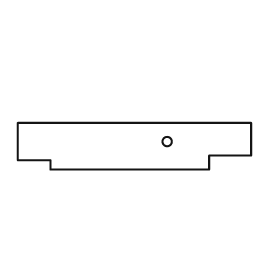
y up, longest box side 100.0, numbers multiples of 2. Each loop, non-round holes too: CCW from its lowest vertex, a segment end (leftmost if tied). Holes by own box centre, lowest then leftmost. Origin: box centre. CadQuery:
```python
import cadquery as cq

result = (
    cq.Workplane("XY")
    .moveTo(-36.0, -10.0)
    .lineTo(32.0, -10.0)
    .lineTo(32.0, -4.0)
    .lineTo(50.0, -4.0)
    .lineTo(50.0, 10.0)
    .lineTo(-50.0, 10.0)
    .lineTo(-50.0, -6.0)
    .lineTo(-36.0, -6.0)
    .close()
    .moveTo(14.0, 2.0)
    .circle(2.0)
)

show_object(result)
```